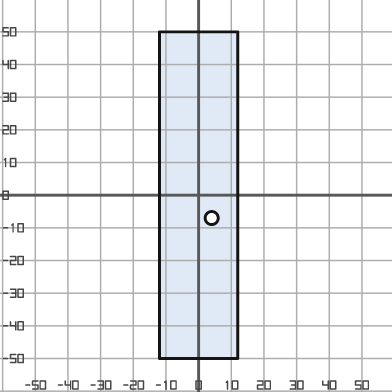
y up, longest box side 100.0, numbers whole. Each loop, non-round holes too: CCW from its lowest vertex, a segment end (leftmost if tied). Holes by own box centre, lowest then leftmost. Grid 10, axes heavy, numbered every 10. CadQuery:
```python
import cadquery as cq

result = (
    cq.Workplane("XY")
    .moveTo(-12.0, -50.0)
    .lineTo(12.0, -50.0)
    .lineTo(12.0, 50.0)
    .lineTo(-12.0, 50.0)
    .close()
    .moveTo(4.0, -7.0)
    .circle(2.0)
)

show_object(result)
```